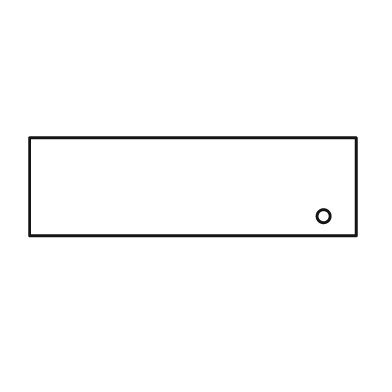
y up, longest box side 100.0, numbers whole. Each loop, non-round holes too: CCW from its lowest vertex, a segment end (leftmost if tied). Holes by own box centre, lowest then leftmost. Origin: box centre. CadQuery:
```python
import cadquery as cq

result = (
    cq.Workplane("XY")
    .moveTo(-50.0, -15.0)
    .lineTo(50.0, -15.0)
    .lineTo(50.0, 15.0)
    .lineTo(-50.0, 15.0)
    .close()
    .moveTo(40.0, -9.0)
    .circle(2.0)
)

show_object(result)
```